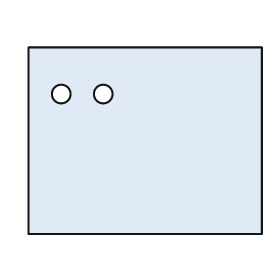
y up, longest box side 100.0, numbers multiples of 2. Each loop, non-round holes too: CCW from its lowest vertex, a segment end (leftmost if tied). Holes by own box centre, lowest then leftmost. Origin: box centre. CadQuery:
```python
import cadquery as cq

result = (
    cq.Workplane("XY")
    .moveTo(-50.0, -40.0)
    .lineTo(50.0, -40.0)
    .lineTo(50.0, 40.0)
    .lineTo(-50.0, 40.0)
    .close()
    .moveTo(-36.0, 20.0)
    .circle(4.0)
    .moveTo(-18.0, 20.0)
    .circle(4.0)
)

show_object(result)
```